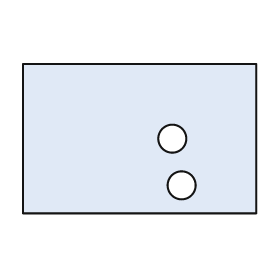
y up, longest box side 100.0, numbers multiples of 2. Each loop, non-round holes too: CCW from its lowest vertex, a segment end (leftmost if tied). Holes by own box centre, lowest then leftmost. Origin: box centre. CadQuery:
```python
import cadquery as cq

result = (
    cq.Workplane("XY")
    .moveTo(-50.0, -32.0)
    .lineTo(50.0, -32.0)
    .lineTo(50.0, 32.0)
    .lineTo(-50.0, 32.0)
    .close()
    .moveTo(18.0, -20.0)
    .circle(6.0)
    .moveTo(14.0, 0.0)
    .circle(6.0)
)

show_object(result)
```